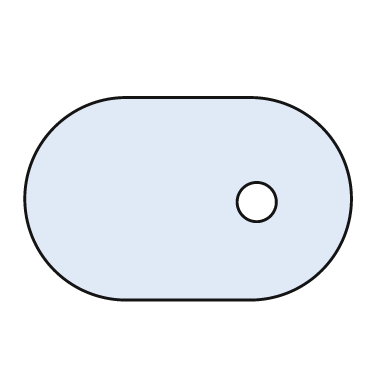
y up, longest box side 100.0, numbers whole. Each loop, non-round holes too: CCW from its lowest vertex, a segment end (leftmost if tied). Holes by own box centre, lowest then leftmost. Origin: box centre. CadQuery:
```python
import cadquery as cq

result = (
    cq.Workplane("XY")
    .moveTo(-19.0, -31.0)
    .lineTo(19.0, -31.0)
    .threePointArc((50.0, 0.0), (19.0, 31.0))
    .lineTo(-19.0, 31.0)
    .threePointArc((-50.0, 0.0), (-19.0, -31.0))
    .close()
    .moveTo(21.0, -1.0)
    .circle(6.0)
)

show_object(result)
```